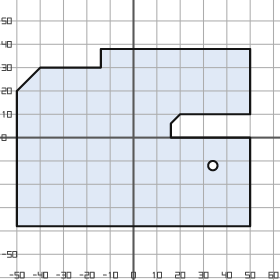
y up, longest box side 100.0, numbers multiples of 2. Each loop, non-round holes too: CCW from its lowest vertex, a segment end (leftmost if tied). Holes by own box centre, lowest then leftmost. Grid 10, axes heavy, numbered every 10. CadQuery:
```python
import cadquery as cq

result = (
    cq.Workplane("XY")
    .moveTo(-50.0, -38.0)
    .lineTo(50.0, -38.0)
    .lineTo(50.0, 0.0)
    .lineTo(16.0, 0.0)
    .lineTo(16.0, 6.0)
    .lineTo(20.0, 10.0)
    .lineTo(50.0, 10.0)
    .lineTo(50.0, 38.0)
    .lineTo(-14.0, 38.0)
    .lineTo(-14.0, 30.0)
    .lineTo(-40.0, 30.0)
    .lineTo(-50.0, 20.0)
    .close()
    .moveTo(34.0, -12.0)
    .circle(2.0)
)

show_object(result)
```